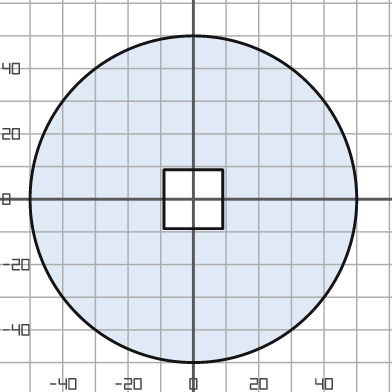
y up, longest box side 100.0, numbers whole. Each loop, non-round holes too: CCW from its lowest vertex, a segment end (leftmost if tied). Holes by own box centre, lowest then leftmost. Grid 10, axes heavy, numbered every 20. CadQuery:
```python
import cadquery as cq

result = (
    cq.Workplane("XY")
    .moveTo(0.0, 0.0)
    .circle(50.0)
    .moveTo(-9.0, -9.0)
    .lineTo(9.0, -9.0)
    .lineTo(9.0, 9.0)
    .lineTo(-9.0, 9.0)
    .close()
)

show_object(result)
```